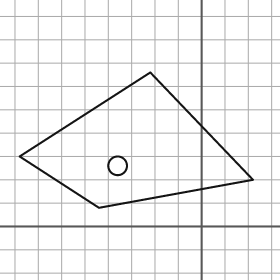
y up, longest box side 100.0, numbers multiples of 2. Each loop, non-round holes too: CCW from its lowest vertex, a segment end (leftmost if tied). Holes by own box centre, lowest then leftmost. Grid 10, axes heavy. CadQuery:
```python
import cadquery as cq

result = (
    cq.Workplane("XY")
    .moveTo(-44.0, 8.0)
    .lineTo(22.0, 20.0)
    .lineTo(-22.0, 66.0)
    .lineTo(-78.0, 30.0)
    .close()
    .moveTo(-36.0, 26.0)
    .circle(4.0)
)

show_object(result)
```